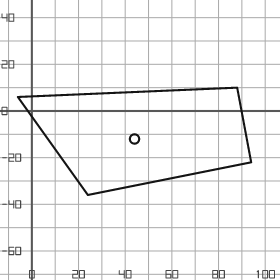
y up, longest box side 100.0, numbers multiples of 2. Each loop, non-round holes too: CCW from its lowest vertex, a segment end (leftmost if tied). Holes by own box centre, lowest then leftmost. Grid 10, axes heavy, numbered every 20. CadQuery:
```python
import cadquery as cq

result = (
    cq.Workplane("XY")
    .moveTo(24.0, -36.0)
    .lineTo(94.0, -22.0)
    .lineTo(88.0, 10.0)
    .lineTo(-6.0, 6.0)
    .close()
    .moveTo(44.0, -12.0)
    .circle(2.0)
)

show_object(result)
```